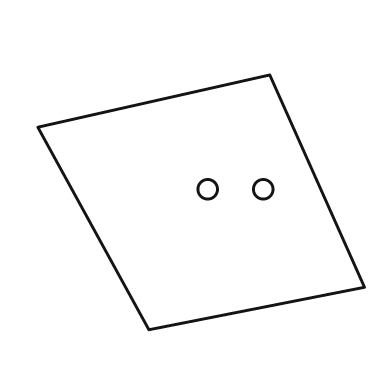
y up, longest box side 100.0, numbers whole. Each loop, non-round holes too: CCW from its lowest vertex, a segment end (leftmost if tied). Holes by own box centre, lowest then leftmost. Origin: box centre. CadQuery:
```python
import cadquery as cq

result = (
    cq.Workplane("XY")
    .moveTo(-16.0, -39.0)
    .lineTo(50.0, -26.0)
    .lineTo(21.0, 39.0)
    .lineTo(-50.0, 23.0)
    .close()
    .moveTo(2.0, 4.0)
    .circle(3.0)
    .moveTo(19.0, 4.0)
    .circle(3.0)
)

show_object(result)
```